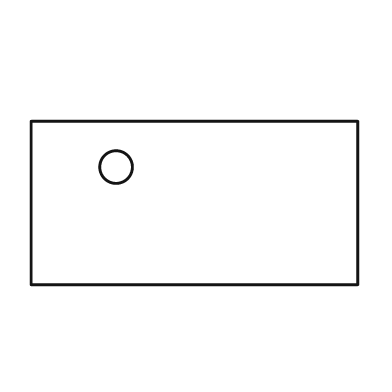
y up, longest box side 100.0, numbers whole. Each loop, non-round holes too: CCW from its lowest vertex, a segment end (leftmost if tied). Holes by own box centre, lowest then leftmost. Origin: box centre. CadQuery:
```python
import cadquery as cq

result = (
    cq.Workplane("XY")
    .moveTo(-50.0, -25.0)
    .lineTo(50.0, -25.0)
    .lineTo(50.0, 25.0)
    .lineTo(-50.0, 25.0)
    .close()
    .moveTo(-24.0, 11.0)
    .circle(5.0)
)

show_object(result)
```